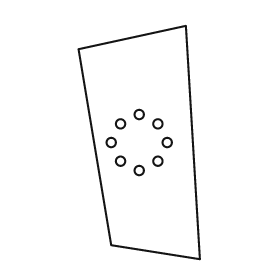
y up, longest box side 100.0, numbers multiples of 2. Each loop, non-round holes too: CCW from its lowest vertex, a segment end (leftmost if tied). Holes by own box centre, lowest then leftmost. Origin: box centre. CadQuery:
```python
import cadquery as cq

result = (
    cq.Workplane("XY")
    .moveTo(26.0, -50.0)
    .lineTo(20.0, 50.0)
    .lineTo(-26.0, 40.0)
    .lineTo(-12.0, -44.0)
    .close()
    .moveTo(0.0, -12.0)
    .circle(2.0)
    .moveTo(-8.0, -8.0)
    .circle(2.0)
    .moveTo(8.0, -8.0)
    .circle(2.0)
    .moveTo(-12.0, 0.0)
    .circle(2.0)
    .moveTo(12.0, 0.0)
    .circle(2.0)
    .moveTo(-8.0, 8.0)
    .circle(2.0)
    .moveTo(8.0, 8.0)
    .circle(2.0)
    .moveTo(0.0, 12.0)
    .circle(2.0)
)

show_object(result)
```